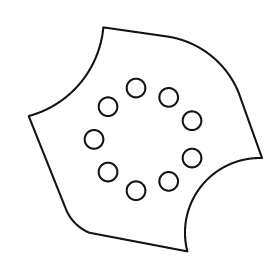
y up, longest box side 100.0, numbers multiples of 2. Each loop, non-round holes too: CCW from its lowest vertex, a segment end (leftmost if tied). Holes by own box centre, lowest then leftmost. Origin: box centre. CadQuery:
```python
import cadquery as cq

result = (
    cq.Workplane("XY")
    .moveTo(18.0, -48.0)
    .threePointArc((24.0, -20.0), (50.0, -8.0))
    .lineTo(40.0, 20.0)
    .threePointArc((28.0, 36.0), (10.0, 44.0))
    .lineTo(-18.0, 48.0)
    .threePointArc((-28.0, 24.0), (-50.0, 10.0))
    .lineTo(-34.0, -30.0)
    .threePointArc((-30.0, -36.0), (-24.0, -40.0))
    .close()
    .moveTo(-4.0, -22.0)
    .circle(4.0)
    .moveTo(10.0, -18.0)
    .circle(4.0)
    .moveTo(-16.0, -14.0)
    .circle(4.0)
    .moveTo(20.0, -8.0)
    .circle(4.0)
    .moveTo(-22.0, 0.0)
    .circle(4.0)
    .moveTo(20.0, 8.0)
    .circle(4.0)
    .moveTo(-16.0, 14.0)
    .circle(4.0)
    .moveTo(10.0, 18.0)
    .circle(4.0)
    .moveTo(-4.0, 22.0)
    .circle(4.0)
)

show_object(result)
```